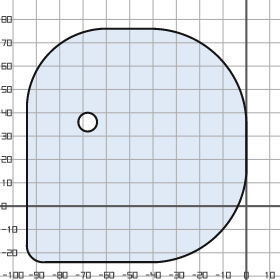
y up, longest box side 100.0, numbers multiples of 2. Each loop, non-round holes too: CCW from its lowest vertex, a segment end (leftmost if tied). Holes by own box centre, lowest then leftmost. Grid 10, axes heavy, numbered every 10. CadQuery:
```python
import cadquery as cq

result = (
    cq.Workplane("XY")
    .moveTo(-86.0, -24.0)
    .lineTo(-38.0, -24.0)
    .threePointArc((-12.0, -12.0), (0.0, 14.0))
    .lineTo(0.0, 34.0)
    .threePointArc((-12.0, 64.0), (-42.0, 76.0))
    .lineTo(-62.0, 76.0)
    .threePointArc((-84.0, 66.0), (-94.0, 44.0))
    .lineTo(-94.0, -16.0)
    .threePointArc((-92.0, -22.0), (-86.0, -24.0))
    .close()
    .moveTo(-68.0, 36.0)
    .circle(4.0)
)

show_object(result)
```